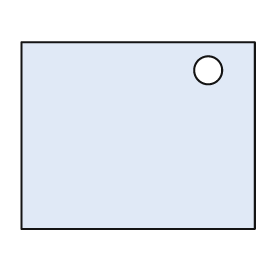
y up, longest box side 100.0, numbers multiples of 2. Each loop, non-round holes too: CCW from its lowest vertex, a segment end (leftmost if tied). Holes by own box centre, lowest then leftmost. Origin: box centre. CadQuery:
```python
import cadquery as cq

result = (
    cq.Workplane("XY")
    .moveTo(-50.0, -40.0)
    .lineTo(50.0, -40.0)
    .lineTo(50.0, 40.0)
    .lineTo(-50.0, 40.0)
    .close()
    .moveTo(30.0, 28.0)
    .circle(6.0)
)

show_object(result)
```